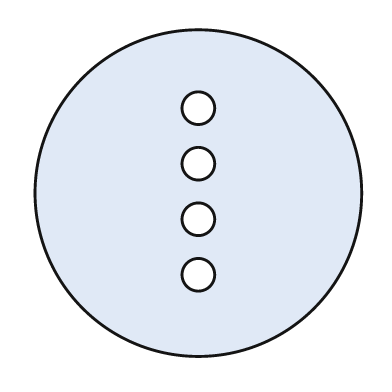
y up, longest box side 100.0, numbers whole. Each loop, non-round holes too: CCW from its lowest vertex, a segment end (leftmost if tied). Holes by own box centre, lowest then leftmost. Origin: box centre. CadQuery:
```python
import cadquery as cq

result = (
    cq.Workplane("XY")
    .moveTo(0.0, 0.0)
    .circle(50.0)
    .moveTo(0.0, -25.0)
    .circle(5.0)
    .moveTo(0.0, -8.0)
    .circle(5.0)
    .moveTo(0.0, 9.0)
    .circle(5.0)
    .moveTo(0.0, 26.0)
    .circle(5.0)
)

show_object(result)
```